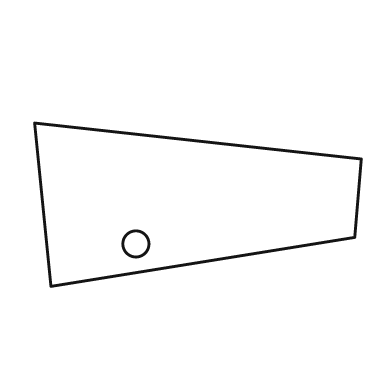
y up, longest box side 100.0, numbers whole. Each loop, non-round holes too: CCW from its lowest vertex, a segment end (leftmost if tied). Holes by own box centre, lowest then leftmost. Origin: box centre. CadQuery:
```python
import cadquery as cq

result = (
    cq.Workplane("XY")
    .moveTo(-45.0, -25.0)
    .lineTo(48.0, -10.0)
    .lineTo(50.0, 14.0)
    .lineTo(-50.0, 25.0)
    .close()
    .moveTo(-19.0, -12.0)
    .circle(4.0)
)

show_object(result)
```